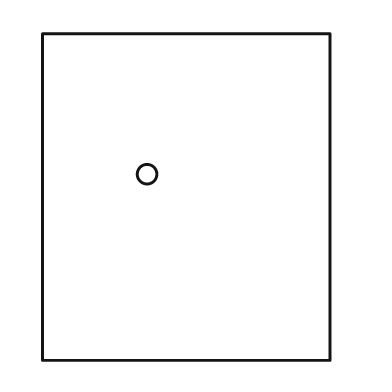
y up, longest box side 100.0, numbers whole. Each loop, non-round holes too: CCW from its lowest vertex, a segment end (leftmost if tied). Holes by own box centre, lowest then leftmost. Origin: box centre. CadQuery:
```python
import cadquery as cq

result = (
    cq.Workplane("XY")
    .moveTo(-44.0, -50.0)
    .lineTo(44.0, -50.0)
    .lineTo(44.0, 50.0)
    .lineTo(-44.0, 50.0)
    .close()
    .moveTo(-12.0, 7.0)
    .circle(3.0)
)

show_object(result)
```